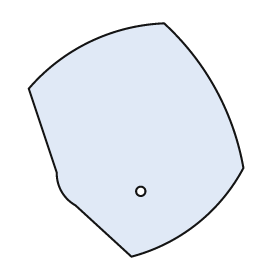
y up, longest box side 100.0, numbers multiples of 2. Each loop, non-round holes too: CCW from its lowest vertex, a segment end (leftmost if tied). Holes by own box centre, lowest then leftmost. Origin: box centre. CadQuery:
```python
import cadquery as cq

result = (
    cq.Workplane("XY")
    .moveTo(-2.0, -50.0)
    .threePointArc((26.0, -36.0), (46.0, -12.0))
    .threePointArc((34.0, 22.0), (12.0, 50.0))
    .threePointArc((-20.0, 42.0), (-46.0, 22.0))
    .lineTo(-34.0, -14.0)
    .threePointArc((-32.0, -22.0), (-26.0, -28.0))
    .close()
    .moveTo(2.0, -22.0)
    .circle(2.0)
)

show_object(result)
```